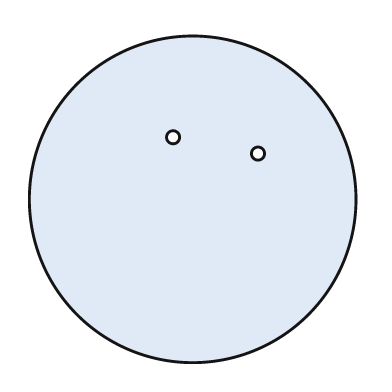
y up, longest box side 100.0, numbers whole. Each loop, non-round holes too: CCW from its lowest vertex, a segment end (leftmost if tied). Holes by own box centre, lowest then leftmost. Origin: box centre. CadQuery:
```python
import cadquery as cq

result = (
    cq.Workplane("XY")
    .moveTo(0.0, 0.0)
    .circle(50.0)
    .moveTo(20.0, 14.0)
    .circle(2.0)
    .moveTo(-6.0, 19.0)
    .circle(2.0)
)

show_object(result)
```